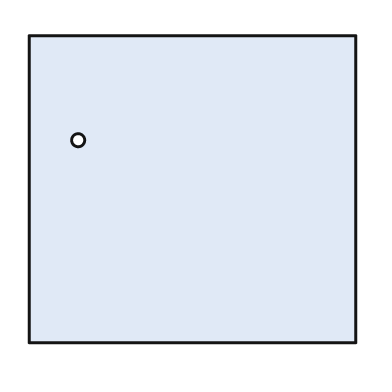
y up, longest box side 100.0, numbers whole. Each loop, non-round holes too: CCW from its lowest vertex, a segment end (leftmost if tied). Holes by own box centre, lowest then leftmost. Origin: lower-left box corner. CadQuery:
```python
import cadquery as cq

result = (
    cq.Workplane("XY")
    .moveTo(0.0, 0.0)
    .lineTo(100.0, 0.0)
    .lineTo(100.0, 94.0)
    .lineTo(0.0, 94.0)
    .close()
    .moveTo(15.0, 62.0)
    .circle(2.0)
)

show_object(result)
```